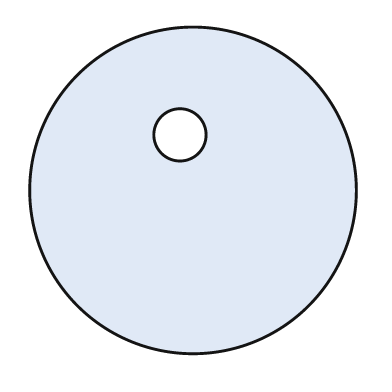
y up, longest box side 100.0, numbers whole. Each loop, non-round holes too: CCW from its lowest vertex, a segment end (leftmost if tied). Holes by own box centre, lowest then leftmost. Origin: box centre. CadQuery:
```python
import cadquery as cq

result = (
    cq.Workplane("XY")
    .moveTo(0.0, 0.0)
    .circle(50.0)
    .moveTo(-4.0, 17.0)
    .circle(8.0)
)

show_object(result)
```